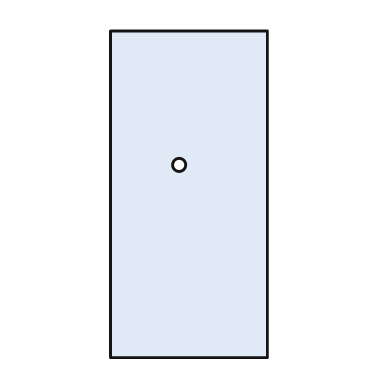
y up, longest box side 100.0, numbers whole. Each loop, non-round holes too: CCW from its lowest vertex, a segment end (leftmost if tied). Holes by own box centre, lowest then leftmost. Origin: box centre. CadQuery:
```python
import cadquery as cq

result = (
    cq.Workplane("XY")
    .moveTo(-24.0, -50.0)
    .lineTo(24.0, -50.0)
    .lineTo(24.0, 50.0)
    .lineTo(-24.0, 50.0)
    .close()
    .moveTo(-3.0, 9.0)
    .circle(2.0)
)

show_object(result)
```